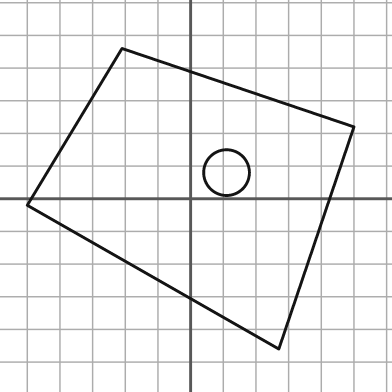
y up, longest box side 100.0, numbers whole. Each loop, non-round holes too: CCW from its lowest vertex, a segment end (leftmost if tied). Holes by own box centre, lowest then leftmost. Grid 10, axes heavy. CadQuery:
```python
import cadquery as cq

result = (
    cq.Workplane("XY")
    .moveTo(27.0, -46.0)
    .lineTo(50.0, 22.0)
    .lineTo(-21.0, 46.0)
    .lineTo(-50.0, -2.0)
    .close()
    .moveTo(11.0, 8.0)
    .circle(7.0)
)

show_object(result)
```